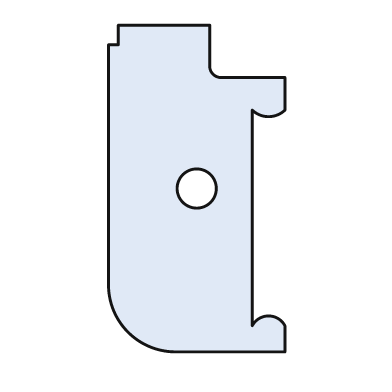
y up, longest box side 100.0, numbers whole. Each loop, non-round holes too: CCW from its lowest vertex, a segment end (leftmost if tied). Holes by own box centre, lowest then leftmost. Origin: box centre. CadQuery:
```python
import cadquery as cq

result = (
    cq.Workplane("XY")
    .moveTo(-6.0, -50.0)
    .lineTo(27.0, -50.0)
    .lineTo(27.0, -42.0)
    .threePointArc((22.0, -39.0), (17.0, -42.0))
    .lineTo(17.0, 24.0)
    .threePointArc((22.0, 22.0), (27.0, 24.0))
    .lineTo(27.0, 34.0)
    .lineTo(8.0, 34.0)
    .threePointArc((5.0, 35.0), (4.0, 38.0))
    .lineTo(4.0, 50.0)
    .lineTo(-24.0, 50.0)
    .lineTo(-24.0, 44.0)
    .lineTo(-27.0, 44.0)
    .lineTo(-27.0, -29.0)
    .threePointArc((-21.0, -44.0), (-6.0, -50.0))
    .close()
    .moveTo(0.0, 0.0)
    .circle(6.0)
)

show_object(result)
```